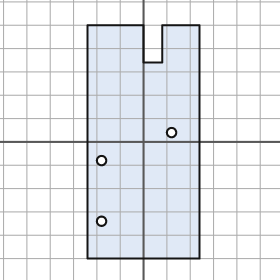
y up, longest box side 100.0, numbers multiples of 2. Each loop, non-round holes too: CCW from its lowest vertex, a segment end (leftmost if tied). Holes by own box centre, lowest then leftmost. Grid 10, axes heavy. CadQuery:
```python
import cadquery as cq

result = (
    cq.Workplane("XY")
    .moveTo(-24.0, -50.0)
    .lineTo(24.0, -50.0)
    .lineTo(24.0, 50.0)
    .lineTo(8.0, 50.0)
    .lineTo(8.0, 34.0)
    .lineTo(0.0, 34.0)
    .lineTo(0.0, 50.0)
    .lineTo(-24.0, 50.0)
    .close()
    .moveTo(-18.0, -34.0)
    .circle(2.0)
    .moveTo(-18.0, -8.0)
    .circle(2.0)
    .moveTo(12.0, 4.0)
    .circle(2.0)
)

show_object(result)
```